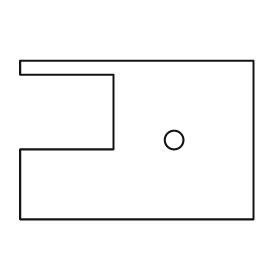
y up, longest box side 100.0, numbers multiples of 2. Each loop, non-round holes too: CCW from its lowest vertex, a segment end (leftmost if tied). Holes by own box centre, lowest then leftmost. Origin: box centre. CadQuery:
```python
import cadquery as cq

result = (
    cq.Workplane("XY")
    .moveTo(-50.0, -34.0)
    .lineTo(50.0, -34.0)
    .lineTo(50.0, 34.0)
    .lineTo(-50.0, 34.0)
    .lineTo(-50.0, 28.0)
    .lineTo(-10.0, 28.0)
    .lineTo(-10.0, -4.0)
    .lineTo(-50.0, -4.0)
    .close()
    .moveTo(16.0, 0.0)
    .circle(4.0)
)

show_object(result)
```